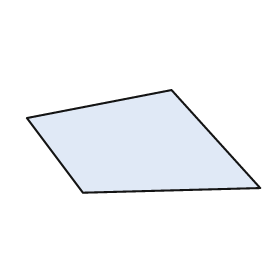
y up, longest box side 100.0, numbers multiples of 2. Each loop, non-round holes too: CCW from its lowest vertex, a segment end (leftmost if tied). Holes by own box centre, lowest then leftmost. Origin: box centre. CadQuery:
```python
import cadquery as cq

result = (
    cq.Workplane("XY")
    .moveTo(-26.0, -22.0)
    .lineTo(50.0, -20.0)
    .lineTo(12.0, 22.0)
    .lineTo(-50.0, 10.0)
    .close()
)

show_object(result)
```